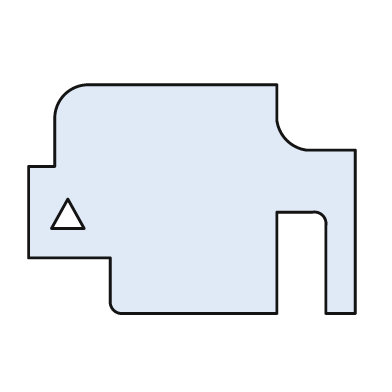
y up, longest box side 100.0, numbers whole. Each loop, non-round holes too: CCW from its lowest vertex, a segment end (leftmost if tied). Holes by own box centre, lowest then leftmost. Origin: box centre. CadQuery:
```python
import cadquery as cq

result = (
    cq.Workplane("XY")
    .moveTo(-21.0, -35.0)
    .lineTo(26.0, -35.0)
    .lineTo(26.0, -4.0)
    .lineTo(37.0, -4.0)
    .threePointArc((40.0, -5.0), (41.0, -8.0))
    .lineTo(41.0, -35.0)
    .lineTo(50.0, -35.0)
    .lineTo(50.0, 15.0)
    .lineTo(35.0, 15.0)
    .threePointArc((29.0, 18.0), (26.0, 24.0))
    .lineTo(26.0, 35.0)
    .lineTo(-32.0, 35.0)
    .threePointArc((-39.0, 32.0), (-42.0, 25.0))
    .lineTo(-42.0, 10.0)
    .lineTo(-50.0, 10.0)
    .lineTo(-50.0, -18.0)
    .lineTo(-25.0, -18.0)
    .lineTo(-25.0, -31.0)
    .threePointArc((-24.0, -34.0), (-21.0, -35.0))
    .close()
    .moveTo(-43.0, -9.0)
    .lineTo(-33.0, -9.0)
    .lineTo(-38.0, 0.0)
    .close()
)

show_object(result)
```